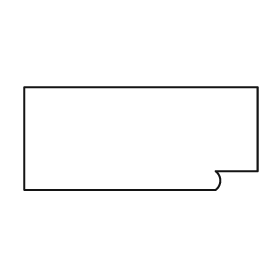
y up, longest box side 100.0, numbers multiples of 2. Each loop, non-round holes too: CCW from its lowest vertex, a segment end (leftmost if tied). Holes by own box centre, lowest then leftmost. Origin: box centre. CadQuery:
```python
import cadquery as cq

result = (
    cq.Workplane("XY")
    .moveTo(-50.0, -22.0)
    .lineTo(32.0, -22.0)
    .threePointArc((34.0, -18.0), (32.0, -14.0))
    .lineTo(50.0, -14.0)
    .lineTo(50.0, 22.0)
    .lineTo(-50.0, 22.0)
    .close()
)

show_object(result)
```